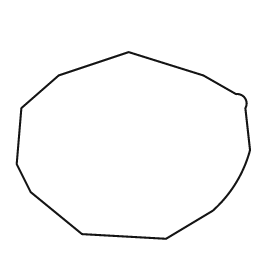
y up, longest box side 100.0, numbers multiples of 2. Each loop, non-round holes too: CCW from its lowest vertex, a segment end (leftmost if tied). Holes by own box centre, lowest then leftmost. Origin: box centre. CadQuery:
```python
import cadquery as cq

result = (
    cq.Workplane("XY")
    .moveTo(14.0, -40.0)
    .lineTo(34.0, -28.0)
    .threePointArc((44.0, -16.0), (50.0, -2.0))
    .lineTo(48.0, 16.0)
    .threePointArc((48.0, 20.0), (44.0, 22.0))
    .lineTo(30.0, 30.0)
    .lineTo(-2.0, 40.0)
    .lineTo(-32.0, 30.0)
    .lineTo(-48.0, 16.0)
    .lineTo(-50.0, -8.0)
    .lineTo(-44.0, -20.0)
    .lineTo(-22.0, -38.0)
    .close()
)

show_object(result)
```